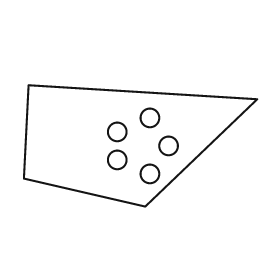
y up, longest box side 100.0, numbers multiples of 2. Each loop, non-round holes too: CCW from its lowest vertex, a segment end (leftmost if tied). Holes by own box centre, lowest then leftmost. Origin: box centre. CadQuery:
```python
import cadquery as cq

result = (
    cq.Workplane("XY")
    .moveTo(2.0, -26.0)
    .lineTo(50.0, 20.0)
    .lineTo(-48.0, 26.0)
    .lineTo(-50.0, -14.0)
    .close()
    .moveTo(4.0, -12.0)
    .circle(4.0)
    .moveTo(-10.0, -6.0)
    .circle(4.0)
    .moveTo(12.0, 0.0)
    .circle(4.0)
    .moveTo(-10.0, 6.0)
    .circle(4.0)
    .moveTo(4.0, 12.0)
    .circle(4.0)
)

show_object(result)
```